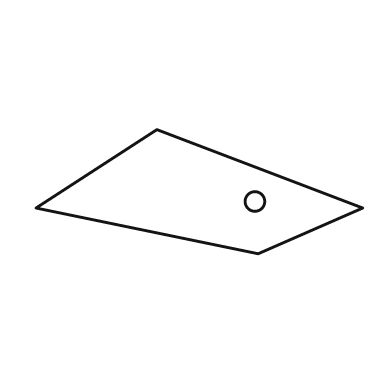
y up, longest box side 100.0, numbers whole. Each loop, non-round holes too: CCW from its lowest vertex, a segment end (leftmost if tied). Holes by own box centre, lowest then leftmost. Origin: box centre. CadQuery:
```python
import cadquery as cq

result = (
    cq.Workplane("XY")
    .moveTo(18.0, -19.0)
    .lineTo(50.0, -5.0)
    .lineTo(-13.0, 19.0)
    .lineTo(-50.0, -5.0)
    .close()
    .moveTo(17.0, -3.0)
    .circle(3.0)
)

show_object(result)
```